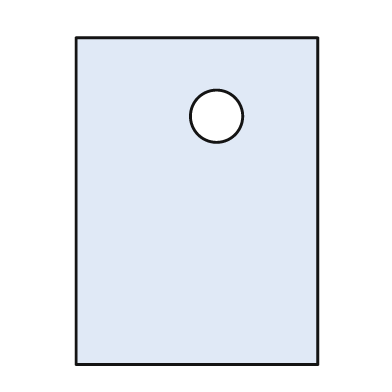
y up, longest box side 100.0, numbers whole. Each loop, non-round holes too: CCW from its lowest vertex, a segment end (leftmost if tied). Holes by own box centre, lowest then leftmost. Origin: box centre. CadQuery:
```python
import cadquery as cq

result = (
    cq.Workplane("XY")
    .moveTo(-37.0, -50.0)
    .lineTo(37.0, -50.0)
    .lineTo(37.0, 50.0)
    .lineTo(-37.0, 50.0)
    .close()
    .moveTo(6.0, 26.0)
    .circle(8.0)
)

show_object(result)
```